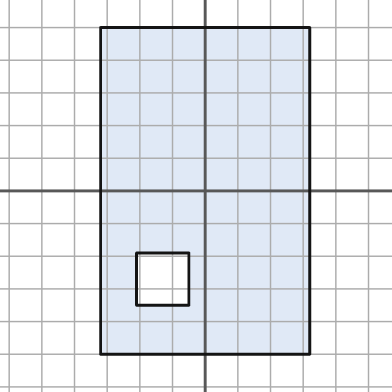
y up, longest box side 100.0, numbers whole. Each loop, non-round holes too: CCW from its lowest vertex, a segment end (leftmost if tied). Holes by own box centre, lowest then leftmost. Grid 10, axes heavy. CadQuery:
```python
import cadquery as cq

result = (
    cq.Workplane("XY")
    .moveTo(-32.0, -50.0)
    .lineTo(32.0, -50.0)
    .lineTo(32.0, 50.0)
    .lineTo(-32.0, 50.0)
    .close()
    .moveTo(-21.0, -35.0)
    .lineTo(-5.0, -35.0)
    .lineTo(-5.0, -19.0)
    .lineTo(-21.0, -19.0)
    .close()
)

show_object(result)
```